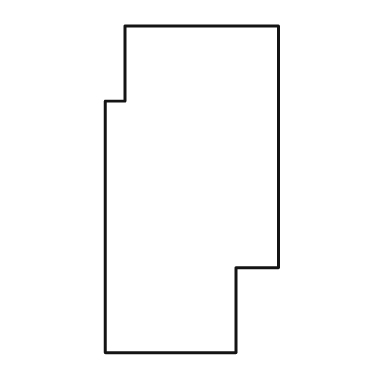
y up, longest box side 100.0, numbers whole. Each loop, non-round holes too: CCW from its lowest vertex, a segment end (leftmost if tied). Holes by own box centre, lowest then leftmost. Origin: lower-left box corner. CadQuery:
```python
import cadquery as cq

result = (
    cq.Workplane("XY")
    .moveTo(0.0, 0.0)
    .lineTo(40.0, 0.0)
    .lineTo(40.0, 26.0)
    .lineTo(53.0, 26.0)
    .lineTo(53.0, 100.0)
    .lineTo(6.0, 100.0)
    .lineTo(6.0, 77.0)
    .lineTo(0.0, 77.0)
    .close()
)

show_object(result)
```